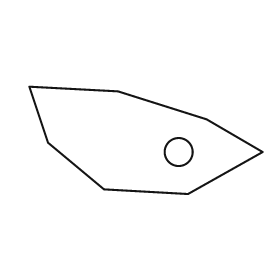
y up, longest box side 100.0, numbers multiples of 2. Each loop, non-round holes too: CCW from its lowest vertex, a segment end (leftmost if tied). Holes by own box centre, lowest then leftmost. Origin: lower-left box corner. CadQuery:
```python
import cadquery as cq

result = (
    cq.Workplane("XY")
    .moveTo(68.0, 0.0)
    .lineTo(100.0, 18.0)
    .lineTo(76.0, 32.0)
    .lineTo(38.0, 44.0)
    .lineTo(0.0, 46.0)
    .lineTo(8.0, 22.0)
    .lineTo(32.0, 2.0)
    .close()
    .moveTo(64.0, 18.0)
    .circle(6.0)
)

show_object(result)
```